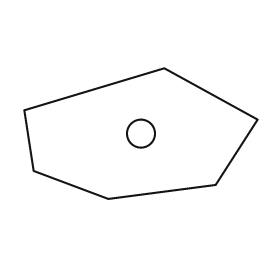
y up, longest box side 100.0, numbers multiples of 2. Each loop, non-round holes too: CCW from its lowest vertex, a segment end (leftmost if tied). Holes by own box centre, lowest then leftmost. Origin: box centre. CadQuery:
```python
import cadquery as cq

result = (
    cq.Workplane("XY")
    .moveTo(-14.0, -28.0)
    .lineTo(32.0, -22.0)
    .lineTo(50.0, 6.0)
    .lineTo(10.0, 28.0)
    .lineTo(-50.0, 10.0)
    .lineTo(-46.0, -16.0)
    .close()
    .moveTo(0.0, 0.0)
    .circle(6.0)
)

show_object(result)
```